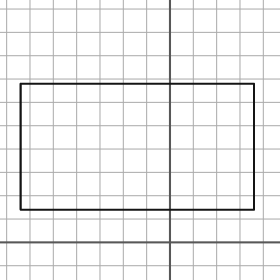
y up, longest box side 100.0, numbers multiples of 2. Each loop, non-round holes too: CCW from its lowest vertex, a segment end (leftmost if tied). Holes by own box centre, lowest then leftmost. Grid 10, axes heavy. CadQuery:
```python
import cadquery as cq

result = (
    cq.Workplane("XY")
    .moveTo(-64.0, 14.0)
    .lineTo(36.0, 14.0)
    .lineTo(36.0, 68.0)
    .lineTo(-64.0, 68.0)
    .close()
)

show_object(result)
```